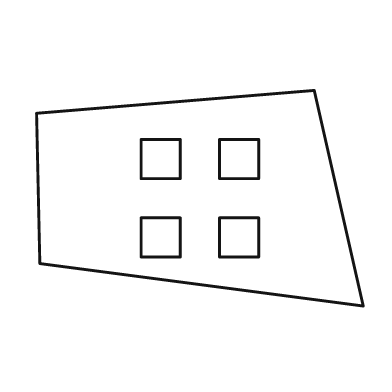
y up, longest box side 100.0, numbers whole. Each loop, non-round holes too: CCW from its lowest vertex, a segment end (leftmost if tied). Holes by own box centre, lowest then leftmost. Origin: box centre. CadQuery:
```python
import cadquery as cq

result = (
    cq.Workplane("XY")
    .moveTo(50.0, -33.0)
    .lineTo(35.0, 33.0)
    .lineTo(-50.0, 26.0)
    .lineTo(-49.0, -20.0)
    .close()
    .moveTo(-18.0, -18.0)
    .lineTo(-6.0, -18.0)
    .lineTo(-6.0, -6.0)
    .lineTo(-18.0, -6.0)
    .close()
    .moveTo(6.0, -18.0)
    .lineTo(18.0, -18.0)
    .lineTo(18.0, -6.0)
    .lineTo(6.0, -6.0)
    .close()
    .moveTo(-18.0, 6.0)
    .lineTo(-6.0, 6.0)
    .lineTo(-6.0, 18.0)
    .lineTo(-18.0, 18.0)
    .close()
    .moveTo(6.0, 6.0)
    .lineTo(18.0, 6.0)
    .lineTo(18.0, 18.0)
    .lineTo(6.0, 18.0)
    .close()
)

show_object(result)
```